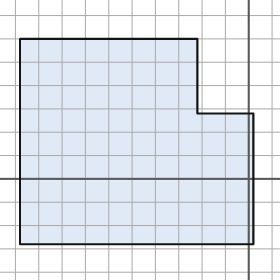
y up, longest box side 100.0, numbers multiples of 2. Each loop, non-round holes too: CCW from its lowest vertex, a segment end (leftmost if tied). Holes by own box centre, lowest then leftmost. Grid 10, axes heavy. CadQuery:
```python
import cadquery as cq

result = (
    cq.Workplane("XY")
    .moveTo(-98.0, -28.0)
    .lineTo(2.0, -28.0)
    .lineTo(2.0, 28.0)
    .lineTo(-22.0, 28.0)
    .lineTo(-22.0, 60.0)
    .lineTo(-98.0, 60.0)
    .close()
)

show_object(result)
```